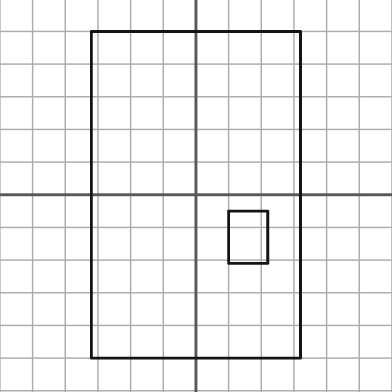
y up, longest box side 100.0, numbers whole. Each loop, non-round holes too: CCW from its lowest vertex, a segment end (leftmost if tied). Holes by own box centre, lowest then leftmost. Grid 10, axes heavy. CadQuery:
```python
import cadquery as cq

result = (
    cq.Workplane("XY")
    .moveTo(-32.0, -50.0)
    .lineTo(32.0, -50.0)
    .lineTo(32.0, 50.0)
    .lineTo(-32.0, 50.0)
    .close()
    .moveTo(10.0, -21.0)
    .lineTo(22.0, -21.0)
    .lineTo(22.0, -5.0)
    .lineTo(10.0, -5.0)
    .close()
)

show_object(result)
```